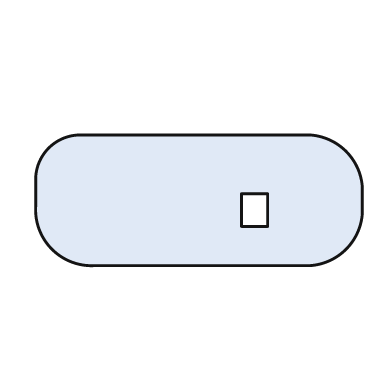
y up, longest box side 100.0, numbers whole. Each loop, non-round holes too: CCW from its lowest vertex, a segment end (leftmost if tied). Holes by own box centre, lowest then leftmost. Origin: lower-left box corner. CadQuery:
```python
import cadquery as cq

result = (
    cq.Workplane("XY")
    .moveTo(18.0, 0.0)
    .lineTo(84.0, 0.0)
    .threePointArc((95.0, 5.0), (100.0, 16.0))
    .lineTo(100.0, 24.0)
    .threePointArc((95.0, 35.0), (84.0, 40.0))
    .lineTo(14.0, 40.0)
    .threePointArc((4.0, 36.0), (0.0, 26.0))
    .lineTo(0.0, 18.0)
    .threePointArc((5.0, 5.0), (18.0, 0.0))
    .close()
    .moveTo(63.0, 12.0)
    .lineTo(71.0, 12.0)
    .lineTo(71.0, 22.0)
    .lineTo(63.0, 22.0)
    .close()
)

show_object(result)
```